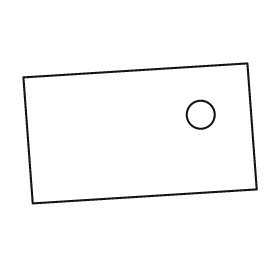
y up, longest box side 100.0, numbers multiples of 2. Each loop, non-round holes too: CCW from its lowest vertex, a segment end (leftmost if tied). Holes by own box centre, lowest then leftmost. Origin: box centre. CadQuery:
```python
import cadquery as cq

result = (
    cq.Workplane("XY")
    .moveTo(-46.0, -30.0)
    .lineTo(50.0, -24.0)
    .lineTo(46.0, 30.0)
    .lineTo(-50.0, 24.0)
    .close()
    .moveTo(26.0, 8.0)
    .circle(6.0)
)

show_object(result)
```